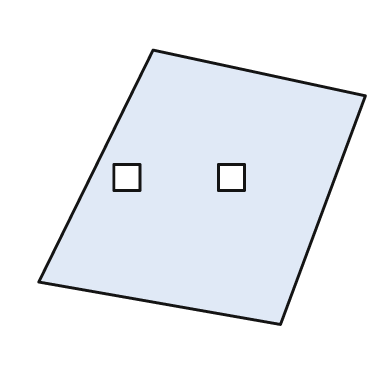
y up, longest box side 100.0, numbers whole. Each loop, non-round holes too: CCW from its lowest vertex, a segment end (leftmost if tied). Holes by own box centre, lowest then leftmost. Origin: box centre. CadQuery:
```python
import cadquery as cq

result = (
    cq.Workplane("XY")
    .moveTo(24.0, -42.0)
    .lineTo(50.0, 28.0)
    .lineTo(-15.0, 42.0)
    .lineTo(-50.0, -29.0)
    .close()
    .moveTo(-27.0, -1.0)
    .lineTo(-19.0, -1.0)
    .lineTo(-19.0, 7.0)
    .lineTo(-27.0, 7.0)
    .close()
    .moveTo(5.0, -1.0)
    .lineTo(13.0, -1.0)
    .lineTo(13.0, 7.0)
    .lineTo(5.0, 7.0)
    .close()
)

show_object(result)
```